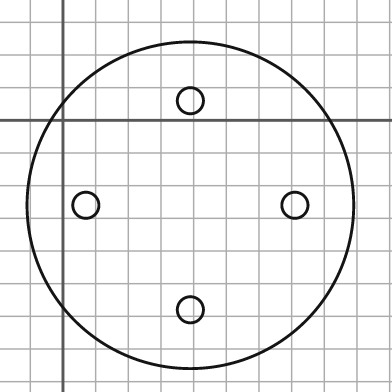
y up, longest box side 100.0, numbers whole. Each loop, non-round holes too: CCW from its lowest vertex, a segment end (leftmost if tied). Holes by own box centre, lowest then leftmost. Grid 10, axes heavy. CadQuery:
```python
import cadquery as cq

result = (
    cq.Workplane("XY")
    .moveTo(39.0, -26.0)
    .circle(50.0)
    .moveTo(39.0, -58.0)
    .circle(4.0)
    .moveTo(7.0, -26.0)
    .circle(4.0)
    .moveTo(71.0, -26.0)
    .circle(4.0)
    .moveTo(39.0, 6.0)
    .circle(4.0)
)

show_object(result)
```